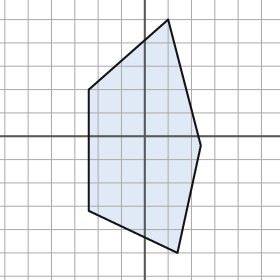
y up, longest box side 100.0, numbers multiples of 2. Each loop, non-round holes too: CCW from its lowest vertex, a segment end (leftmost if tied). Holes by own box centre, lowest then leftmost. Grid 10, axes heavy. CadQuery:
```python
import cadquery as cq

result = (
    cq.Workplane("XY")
    .moveTo(14.0, -50.0)
    .lineTo(24.0, -4.0)
    .lineTo(10.0, 50.0)
    .lineTo(-24.0, 20.0)
    .lineTo(-24.0, -32.0)
    .close()
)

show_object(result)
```